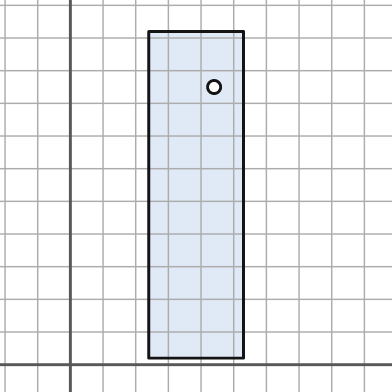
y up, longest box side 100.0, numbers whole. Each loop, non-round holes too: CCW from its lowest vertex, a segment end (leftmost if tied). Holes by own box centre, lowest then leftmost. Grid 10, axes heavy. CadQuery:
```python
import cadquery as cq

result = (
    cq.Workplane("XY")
    .moveTo(24.0, 2.0)
    .lineTo(53.0, 2.0)
    .lineTo(53.0, 102.0)
    .lineTo(24.0, 102.0)
    .close()
    .moveTo(44.0, 85.0)
    .circle(2.0)
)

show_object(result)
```